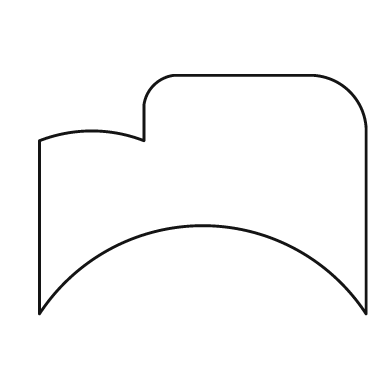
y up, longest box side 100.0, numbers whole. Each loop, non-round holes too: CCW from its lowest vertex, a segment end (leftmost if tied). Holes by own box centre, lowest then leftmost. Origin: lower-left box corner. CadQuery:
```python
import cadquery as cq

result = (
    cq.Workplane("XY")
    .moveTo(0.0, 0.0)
    .threePointArc((50.0, 27.0), (100.0, 0.0))
    .lineTo(100.0, 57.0)
    .threePointArc((95.0, 68.0), (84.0, 73.0))
    .lineTo(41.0, 73.0)
    .threePointArc((35.0, 70.0), (32.0, 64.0))
    .lineTo(32.0, 53.0)
    .threePointArc((16.0, 56.0), (0.0, 53.0))
    .close()
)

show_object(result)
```